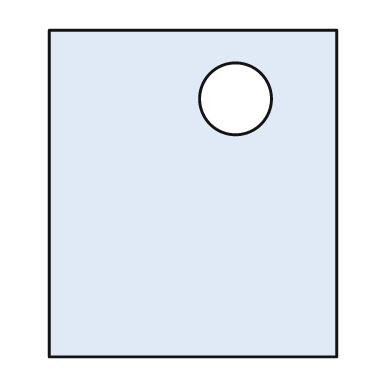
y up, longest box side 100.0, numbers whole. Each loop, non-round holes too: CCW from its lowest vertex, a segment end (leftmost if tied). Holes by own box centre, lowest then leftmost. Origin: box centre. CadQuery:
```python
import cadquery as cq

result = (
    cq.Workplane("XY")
    .moveTo(-44.0, -50.0)
    .lineTo(44.0, -50.0)
    .lineTo(44.0, 50.0)
    .lineTo(-44.0, 50.0)
    .close()
    .moveTo(13.0, 29.0)
    .circle(11.0)
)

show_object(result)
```